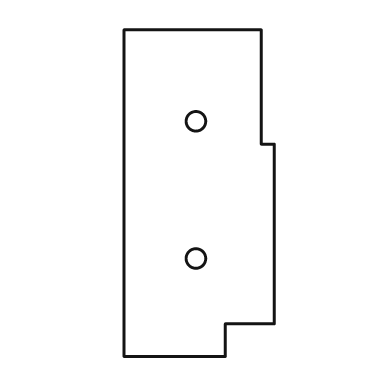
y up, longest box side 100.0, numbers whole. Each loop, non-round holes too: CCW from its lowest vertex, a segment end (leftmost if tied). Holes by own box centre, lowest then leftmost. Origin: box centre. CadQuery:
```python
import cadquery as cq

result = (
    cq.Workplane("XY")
    .moveTo(-23.0, -50.0)
    .lineTo(8.0, -50.0)
    .lineTo(8.0, -40.0)
    .lineTo(23.0, -40.0)
    .lineTo(23.0, 15.0)
    .lineTo(19.0, 15.0)
    .lineTo(19.0, 50.0)
    .lineTo(-23.0, 50.0)
    .close()
    .moveTo(-1.0, -20.0)
    .circle(3.0)
    .moveTo(-1.0, 22.0)
    .circle(3.0)
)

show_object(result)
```